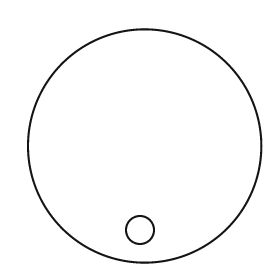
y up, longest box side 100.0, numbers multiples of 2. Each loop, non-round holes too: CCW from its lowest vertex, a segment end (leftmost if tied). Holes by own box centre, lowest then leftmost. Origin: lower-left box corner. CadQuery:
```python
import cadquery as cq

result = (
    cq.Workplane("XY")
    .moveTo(50.0, 50.0)
    .circle(50.0)
    .moveTo(48.0, 14.0)
    .circle(6.0)
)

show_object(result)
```